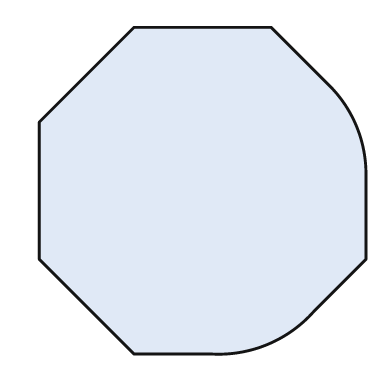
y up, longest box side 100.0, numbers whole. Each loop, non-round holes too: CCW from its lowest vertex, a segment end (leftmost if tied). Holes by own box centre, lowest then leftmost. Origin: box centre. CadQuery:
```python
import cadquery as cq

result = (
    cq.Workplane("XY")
    .moveTo(-21.0, -50.0)
    .lineTo(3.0, -50.0)
    .threePointArc((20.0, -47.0), (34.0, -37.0))
    .lineTo(50.0, -21.0)
    .lineTo(50.0, 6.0)
    .threePointArc((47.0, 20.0), (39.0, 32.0))
    .lineTo(21.0, 50.0)
    .lineTo(-21.0, 50.0)
    .lineTo(-50.0, 21.0)
    .lineTo(-50.0, -21.0)
    .close()
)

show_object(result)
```